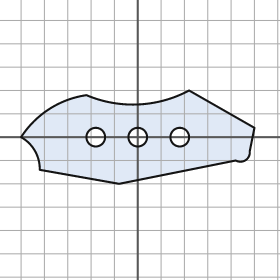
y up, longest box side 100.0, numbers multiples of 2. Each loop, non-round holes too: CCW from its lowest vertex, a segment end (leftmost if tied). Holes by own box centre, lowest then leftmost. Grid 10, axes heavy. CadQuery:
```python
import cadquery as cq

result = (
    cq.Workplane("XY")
    .moveTo(-8.0, -20.0)
    .lineTo(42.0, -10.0)
    .threePointArc((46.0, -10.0), (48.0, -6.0))
    .lineTo(50.0, 4.0)
    .lineTo(22.0, 20.0)
    .threePointArc((0.0, 14.0), (-22.0, 18.0))
    .threePointArc((-38.0, 12.0), (-50.0, 0.0))
    .threePointArc((-44.0, -6.0), (-42.0, -14.0))
    .close()
    .moveTo(-18.0, 0.0)
    .circle(4.0)
    .moveTo(0.0, 0.0)
    .circle(4.0)
    .moveTo(18.0, 0.0)
    .circle(4.0)
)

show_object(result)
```